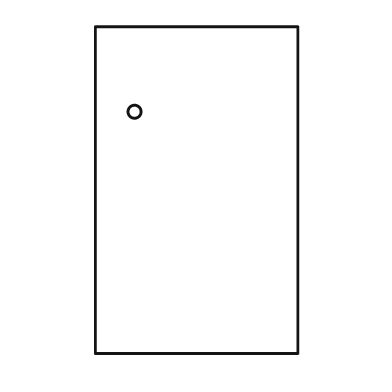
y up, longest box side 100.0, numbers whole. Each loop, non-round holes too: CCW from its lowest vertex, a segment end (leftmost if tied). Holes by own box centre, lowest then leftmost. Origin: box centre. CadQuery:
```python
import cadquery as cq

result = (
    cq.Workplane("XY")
    .moveTo(-31.0, -50.0)
    .lineTo(31.0, -50.0)
    .lineTo(31.0, 50.0)
    .lineTo(-31.0, 50.0)
    .close()
    .moveTo(-19.0, 24.0)
    .circle(2.0)
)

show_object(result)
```